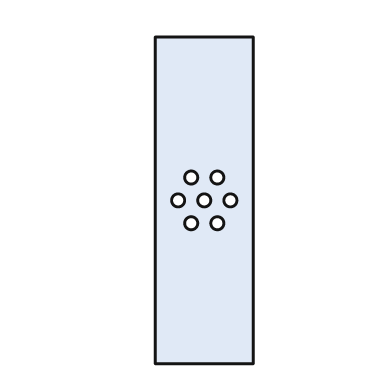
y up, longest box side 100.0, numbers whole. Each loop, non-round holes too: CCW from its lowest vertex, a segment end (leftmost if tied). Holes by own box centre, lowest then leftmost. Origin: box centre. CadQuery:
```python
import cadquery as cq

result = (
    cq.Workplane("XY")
    .moveTo(-15.0, -50.0)
    .lineTo(15.0, -50.0)
    .lineTo(15.0, 50.0)
    .lineTo(-15.0, 50.0)
    .close()
    .moveTo(-4.0, -7.0)
    .circle(2.0)
    .moveTo(4.0, -7.0)
    .circle(2.0)
    .moveTo(-8.0, 0.0)
    .circle(2.0)
    .moveTo(0.0, 0.0)
    .circle(2.0)
    .moveTo(8.0, 0.0)
    .circle(2.0)
    .moveTo(-4.0, 7.0)
    .circle(2.0)
    .moveTo(4.0, 7.0)
    .circle(2.0)
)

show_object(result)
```